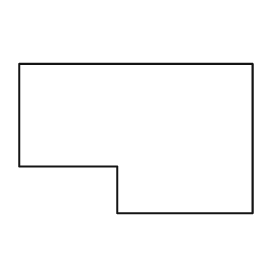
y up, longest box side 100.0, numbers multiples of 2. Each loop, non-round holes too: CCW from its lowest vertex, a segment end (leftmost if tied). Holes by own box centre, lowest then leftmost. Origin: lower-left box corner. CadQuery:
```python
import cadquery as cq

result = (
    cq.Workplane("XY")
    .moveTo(42.0, 0.0)
    .lineTo(100.0, 0.0)
    .lineTo(100.0, 64.0)
    .lineTo(0.0, 64.0)
    .lineTo(0.0, 20.0)
    .lineTo(42.0, 20.0)
    .close()
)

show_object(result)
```